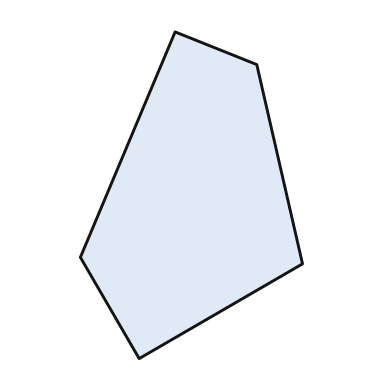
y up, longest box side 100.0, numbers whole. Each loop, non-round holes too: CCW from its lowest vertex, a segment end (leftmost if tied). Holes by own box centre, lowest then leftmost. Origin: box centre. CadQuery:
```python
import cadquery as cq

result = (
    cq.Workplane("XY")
    .moveTo(-16.0, -50.0)
    .lineTo(34.0, -21.0)
    .lineTo(20.0, 40.0)
    .lineTo(-5.0, 50.0)
    .lineTo(-34.0, -19.0)
    .close()
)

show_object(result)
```